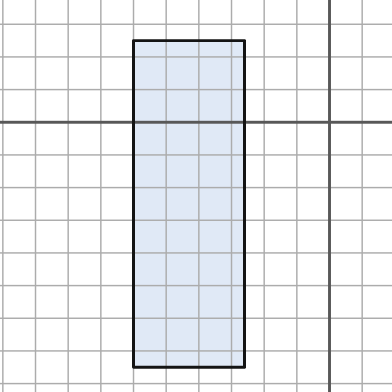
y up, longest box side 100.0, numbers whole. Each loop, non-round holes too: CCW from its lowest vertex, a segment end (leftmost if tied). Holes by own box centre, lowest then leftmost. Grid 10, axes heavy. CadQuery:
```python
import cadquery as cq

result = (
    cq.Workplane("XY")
    .moveTo(-60.0, -75.0)
    .lineTo(-26.0, -75.0)
    .lineTo(-26.0, 25.0)
    .lineTo(-60.0, 25.0)
    .close()
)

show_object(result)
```